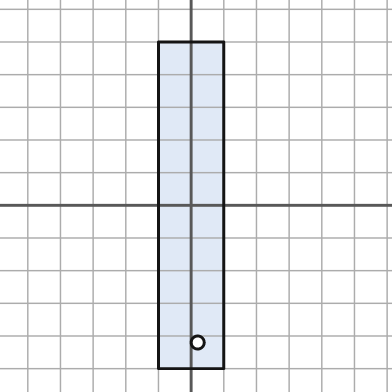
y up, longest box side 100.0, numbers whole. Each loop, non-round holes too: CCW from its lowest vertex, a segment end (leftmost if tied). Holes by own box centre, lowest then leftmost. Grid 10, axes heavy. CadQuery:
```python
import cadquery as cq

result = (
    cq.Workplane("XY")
    .moveTo(-10.0, -50.0)
    .lineTo(10.0, -50.0)
    .lineTo(10.0, 50.0)
    .lineTo(-10.0, 50.0)
    .close()
    .moveTo(2.0, -42.0)
    .circle(2.0)
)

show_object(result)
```